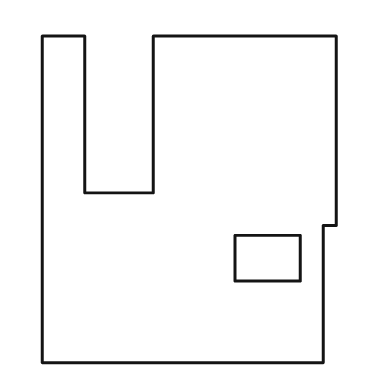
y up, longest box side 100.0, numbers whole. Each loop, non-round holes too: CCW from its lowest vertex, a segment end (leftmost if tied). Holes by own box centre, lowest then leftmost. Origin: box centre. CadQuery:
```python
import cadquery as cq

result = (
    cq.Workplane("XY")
    .moveTo(-45.0, -50.0)
    .lineTo(41.0, -50.0)
    .lineTo(41.0, -8.0)
    .lineTo(45.0, -8.0)
    .lineTo(45.0, 50.0)
    .lineTo(-11.0, 50.0)
    .lineTo(-11.0, 2.0)
    .lineTo(-32.0, 2.0)
    .lineTo(-32.0, 50.0)
    .lineTo(-45.0, 50.0)
    .close()
    .moveTo(14.0, -25.0)
    .lineTo(34.0, -25.0)
    .lineTo(34.0, -11.0)
    .lineTo(14.0, -11.0)
    .close()
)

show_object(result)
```